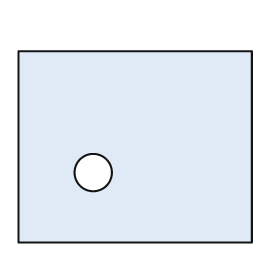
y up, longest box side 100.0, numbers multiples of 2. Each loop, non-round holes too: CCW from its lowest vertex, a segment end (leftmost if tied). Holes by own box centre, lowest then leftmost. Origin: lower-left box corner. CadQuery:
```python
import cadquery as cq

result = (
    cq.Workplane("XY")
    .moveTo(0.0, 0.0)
    .lineTo(100.0, 0.0)
    .lineTo(100.0, 82.0)
    .lineTo(0.0, 82.0)
    .close()
    .moveTo(32.0, 30.0)
    .circle(8.0)
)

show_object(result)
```